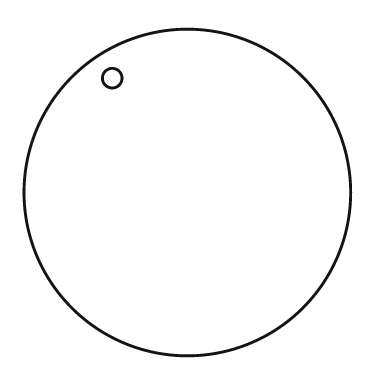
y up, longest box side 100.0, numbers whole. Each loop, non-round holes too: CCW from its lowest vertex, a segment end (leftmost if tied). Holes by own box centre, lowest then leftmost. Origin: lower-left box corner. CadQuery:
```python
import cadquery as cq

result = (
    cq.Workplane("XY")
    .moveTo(50.0, 50.0)
    .circle(50.0)
    .moveTo(27.0, 85.0)
    .circle(3.0)
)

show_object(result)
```